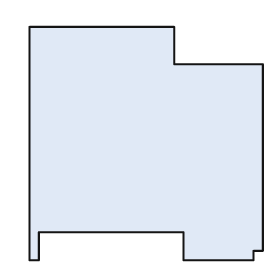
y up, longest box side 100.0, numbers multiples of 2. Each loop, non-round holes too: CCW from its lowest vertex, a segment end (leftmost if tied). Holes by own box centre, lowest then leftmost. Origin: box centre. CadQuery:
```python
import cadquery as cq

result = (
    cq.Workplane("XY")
    .moveTo(-50.0, -50.0)
    .lineTo(-46.0, -50.0)
    .lineTo(-46.0, -38.0)
    .lineTo(16.0, -38.0)
    .lineTo(16.0, -50.0)
    .lineTo(46.0, -50.0)
    .lineTo(46.0, -46.0)
    .lineTo(50.0, -46.0)
    .lineTo(50.0, 34.0)
    .lineTo(12.0, 34.0)
    .lineTo(12.0, 50.0)
    .lineTo(-50.0, 50.0)
    .close()
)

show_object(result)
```